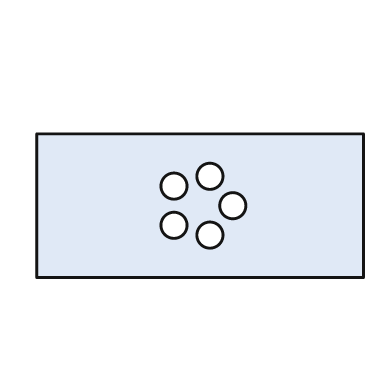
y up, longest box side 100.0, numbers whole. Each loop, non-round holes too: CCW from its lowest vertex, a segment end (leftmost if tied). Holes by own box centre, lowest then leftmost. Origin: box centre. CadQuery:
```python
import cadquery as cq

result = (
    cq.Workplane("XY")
    .moveTo(-50.0, -22.0)
    .lineTo(50.0, -22.0)
    .lineTo(50.0, 22.0)
    .lineTo(-50.0, 22.0)
    .close()
    .moveTo(3.0, -9.0)
    .circle(4.0)
    .moveTo(-8.0, -6.0)
    .circle(4.0)
    .moveTo(10.0, 0.0)
    .circle(4.0)
    .moveTo(-8.0, 6.0)
    .circle(4.0)
    .moveTo(3.0, 9.0)
    .circle(4.0)
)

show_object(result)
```